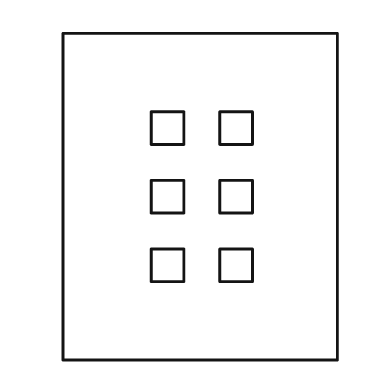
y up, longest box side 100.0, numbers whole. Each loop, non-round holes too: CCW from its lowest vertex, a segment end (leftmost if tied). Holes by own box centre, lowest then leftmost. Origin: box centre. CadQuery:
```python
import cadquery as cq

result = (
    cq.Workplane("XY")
    .moveTo(-42.0, -50.0)
    .lineTo(42.0, -50.0)
    .lineTo(42.0, 50.0)
    .lineTo(-42.0, 50.0)
    .close()
    .moveTo(-15.0, -26.0)
    .lineTo(-5.0, -26.0)
    .lineTo(-5.0, -16.0)
    .lineTo(-15.0, -16.0)
    .close()
    .moveTo(6.0, -26.0)
    .lineTo(16.0, -26.0)
    .lineTo(16.0, -16.0)
    .lineTo(6.0, -16.0)
    .close()
    .moveTo(-15.0, -5.0)
    .lineTo(-5.0, -5.0)
    .lineTo(-5.0, 5.0)
    .lineTo(-15.0, 5.0)
    .close()
    .moveTo(6.0, -5.0)
    .lineTo(16.0, -5.0)
    .lineTo(16.0, 5.0)
    .lineTo(6.0, 5.0)
    .close()
    .moveTo(-15.0, 16.0)
    .lineTo(-5.0, 16.0)
    .lineTo(-5.0, 26.0)
    .lineTo(-15.0, 26.0)
    .close()
    .moveTo(6.0, 16.0)
    .lineTo(16.0, 16.0)
    .lineTo(16.0, 26.0)
    .lineTo(6.0, 26.0)
    .close()
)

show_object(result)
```